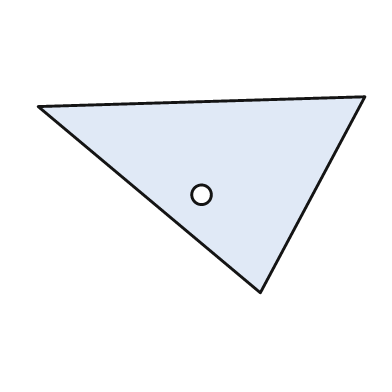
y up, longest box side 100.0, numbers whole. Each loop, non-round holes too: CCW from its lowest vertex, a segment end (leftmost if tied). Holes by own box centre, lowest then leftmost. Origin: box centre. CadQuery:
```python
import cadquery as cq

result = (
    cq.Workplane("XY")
    .moveTo(18.0, -30.0)
    .lineTo(50.0, 30.0)
    .lineTo(-50.0, 27.0)
    .close()
    .moveTo(0.0, 0.0)
    .circle(3.0)
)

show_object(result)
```